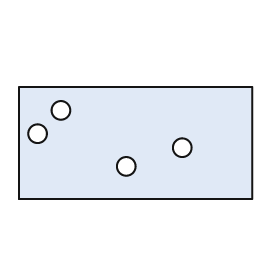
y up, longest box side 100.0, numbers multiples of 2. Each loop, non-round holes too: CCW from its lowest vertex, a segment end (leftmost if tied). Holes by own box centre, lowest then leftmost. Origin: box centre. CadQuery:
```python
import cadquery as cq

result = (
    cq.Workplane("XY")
    .moveTo(-50.0, -24.0)
    .lineTo(50.0, -24.0)
    .lineTo(50.0, 24.0)
    .lineTo(-50.0, 24.0)
    .close()
    .moveTo(-4.0, -10.0)
    .circle(4.0)
    .moveTo(20.0, -2.0)
    .circle(4.0)
    .moveTo(-42.0, 4.0)
    .circle(4.0)
    .moveTo(-32.0, 14.0)
    .circle(4.0)
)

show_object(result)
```